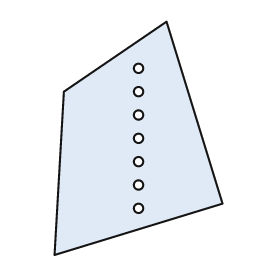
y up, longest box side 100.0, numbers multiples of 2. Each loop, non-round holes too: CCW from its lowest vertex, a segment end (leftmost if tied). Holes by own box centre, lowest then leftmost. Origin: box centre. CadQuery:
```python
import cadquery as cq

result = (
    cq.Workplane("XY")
    .moveTo(-36.0, -50.0)
    .lineTo(36.0, -28.0)
    .lineTo(12.0, 50.0)
    .lineTo(-32.0, 20.0)
    .close()
    .moveTo(0.0, -30.0)
    .circle(2.0)
    .moveTo(0.0, -20.0)
    .circle(2.0)
    .moveTo(0.0, -10.0)
    .circle(2.0)
    .moveTo(0.0, 0.0)
    .circle(2.0)
    .moveTo(0.0, 10.0)
    .circle(2.0)
    .moveTo(0.0, 20.0)
    .circle(2.0)
    .moveTo(0.0, 30.0)
    .circle(2.0)
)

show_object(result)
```